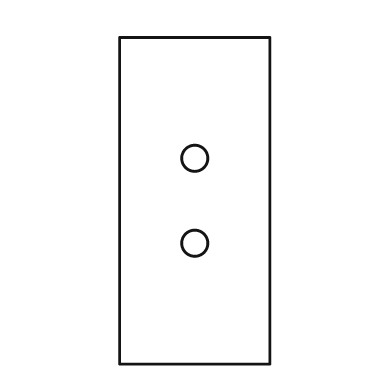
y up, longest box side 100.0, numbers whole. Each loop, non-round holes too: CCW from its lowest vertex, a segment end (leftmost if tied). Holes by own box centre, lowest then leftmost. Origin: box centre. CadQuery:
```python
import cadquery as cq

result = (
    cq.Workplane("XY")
    .moveTo(-23.0, -50.0)
    .lineTo(23.0, -50.0)
    .lineTo(23.0, 50.0)
    .lineTo(-23.0, 50.0)
    .close()
    .moveTo(0.0, -13.0)
    .circle(4.0)
    .moveTo(0.0, 13.0)
    .circle(4.0)
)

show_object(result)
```